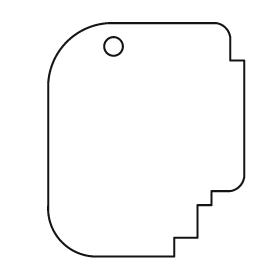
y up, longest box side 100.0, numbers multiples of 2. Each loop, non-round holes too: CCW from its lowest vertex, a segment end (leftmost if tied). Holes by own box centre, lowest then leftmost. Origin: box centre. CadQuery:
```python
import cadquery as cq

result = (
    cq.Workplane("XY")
    .moveTo(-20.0, -50.0)
    .lineTo(12.0, -50.0)
    .lineTo(12.0, -42.0)
    .lineTo(22.0, -42.0)
    .lineTo(22.0, -28.0)
    .lineTo(28.0, -28.0)
    .lineTo(28.0, -22.0)
    .lineTo(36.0, -22.0)
    .threePointArc((40.0, -20.0), (42.0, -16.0))
    .lineTo(42.0, 34.0)
    .lineTo(36.0, 34.0)
    .lineTo(36.0, 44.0)
    .threePointArc((34.0, 48.0), (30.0, 50.0))
    .lineTo(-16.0, 50.0)
    .threePointArc((-34.0, 42.0), (-42.0, 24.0))
    .lineTo(-42.0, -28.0)
    .threePointArc((-36.0, -44.0), (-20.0, -50.0))
    .close()
    .moveTo(-14.0, 40.0)
    .circle(4.0)
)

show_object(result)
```